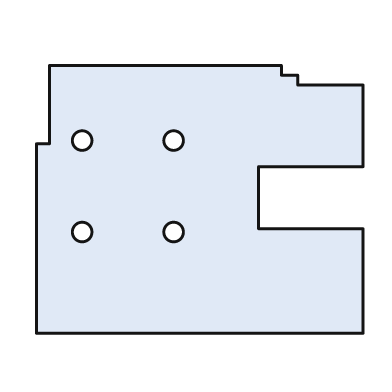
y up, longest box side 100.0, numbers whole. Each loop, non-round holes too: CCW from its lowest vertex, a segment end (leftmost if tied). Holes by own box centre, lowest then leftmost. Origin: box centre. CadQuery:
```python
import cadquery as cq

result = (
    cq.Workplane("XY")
    .moveTo(-50.0, -41.0)
    .lineTo(50.0, -41.0)
    .lineTo(50.0, -9.0)
    .lineTo(18.0, -9.0)
    .lineTo(18.0, 10.0)
    .lineTo(50.0, 10.0)
    .lineTo(50.0, 35.0)
    .lineTo(30.0, 35.0)
    .lineTo(30.0, 38.0)
    .lineTo(25.0, 38.0)
    .lineTo(25.0, 41.0)
    .lineTo(-46.0, 41.0)
    .lineTo(-46.0, 17.0)
    .lineTo(-50.0, 17.0)
    .close()
    .moveTo(-36.0, -10.0)
    .circle(3.0)
    .moveTo(-8.0, -10.0)
    .circle(3.0)
    .moveTo(-36.0, 18.0)
    .circle(3.0)
    .moveTo(-8.0, 18.0)
    .circle(3.0)
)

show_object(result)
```